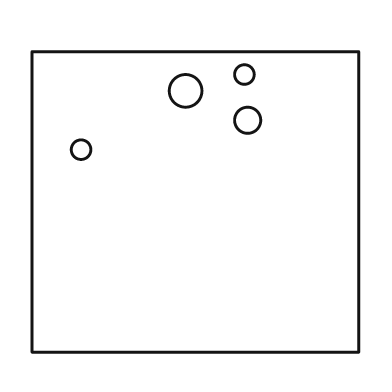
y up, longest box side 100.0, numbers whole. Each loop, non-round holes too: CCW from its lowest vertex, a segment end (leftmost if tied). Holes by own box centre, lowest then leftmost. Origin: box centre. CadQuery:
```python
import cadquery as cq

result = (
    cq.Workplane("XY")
    .moveTo(-50.0, -46.0)
    .lineTo(50.0, -46.0)
    .lineTo(50.0, 46.0)
    .lineTo(-50.0, 46.0)
    .close()
    .moveTo(-35.0, 16.0)
    .circle(3.0)
    .moveTo(16.0, 25.0)
    .circle(4.0)
    .moveTo(-3.0, 34.0)
    .circle(5.0)
    .moveTo(15.0, 39.0)
    .circle(3.0)
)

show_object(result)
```